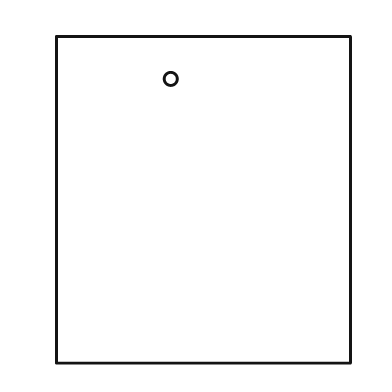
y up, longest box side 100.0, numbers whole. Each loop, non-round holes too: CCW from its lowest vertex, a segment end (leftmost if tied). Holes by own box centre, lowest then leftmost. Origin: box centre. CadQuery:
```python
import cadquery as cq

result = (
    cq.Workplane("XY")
    .moveTo(-45.0, -50.0)
    .lineTo(45.0, -50.0)
    .lineTo(45.0, 50.0)
    .lineTo(-45.0, 50.0)
    .close()
    .moveTo(-10.0, 37.0)
    .circle(2.0)
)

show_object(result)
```